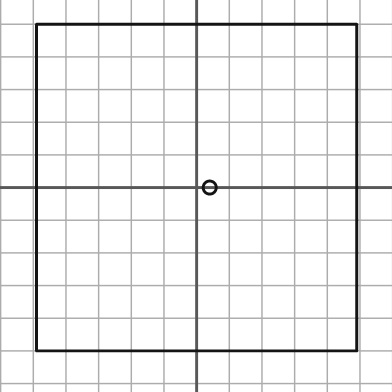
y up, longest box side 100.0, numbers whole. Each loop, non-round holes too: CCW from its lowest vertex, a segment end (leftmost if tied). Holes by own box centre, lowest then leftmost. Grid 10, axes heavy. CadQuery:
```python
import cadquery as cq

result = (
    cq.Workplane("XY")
    .moveTo(-49.0, -50.0)
    .lineTo(49.0, -50.0)
    .lineTo(49.0, 50.0)
    .lineTo(-49.0, 50.0)
    .close()
    .moveTo(4.0, 0.0)
    .circle(2.0)
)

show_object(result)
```